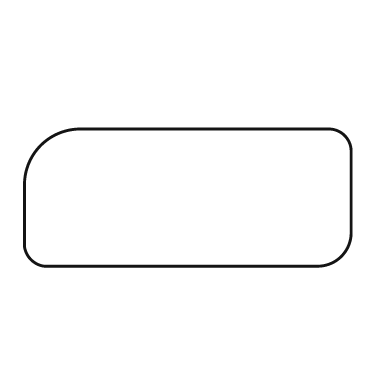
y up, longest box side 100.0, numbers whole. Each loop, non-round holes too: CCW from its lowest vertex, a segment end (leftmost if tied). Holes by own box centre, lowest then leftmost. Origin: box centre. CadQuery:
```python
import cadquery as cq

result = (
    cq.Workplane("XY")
    .moveTo(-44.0, -21.0)
    .lineTo(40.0, -21.0)
    .threePointArc((47.0, -18.0), (50.0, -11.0))
    .lineTo(50.0, 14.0)
    .threePointArc((48.0, 19.0), (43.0, 21.0))
    .lineTo(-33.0, 21.0)
    .threePointArc((-45.0, 16.0), (-50.0, 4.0))
    .lineTo(-50.0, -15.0)
    .threePointArc((-48.0, -19.0), (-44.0, -21.0))
    .close()
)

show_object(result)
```